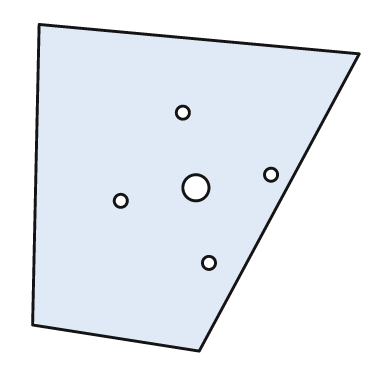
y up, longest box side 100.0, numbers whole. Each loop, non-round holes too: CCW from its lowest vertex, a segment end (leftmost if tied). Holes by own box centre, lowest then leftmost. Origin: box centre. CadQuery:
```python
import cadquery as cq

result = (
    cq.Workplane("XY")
    .moveTo(1.0, -50.0)
    .lineTo(50.0, 41.0)
    .lineTo(-48.0, 50.0)
    .lineTo(-50.0, -42.0)
    .close()
    .moveTo(4.0, -23.0)
    .circle(2.0)
    .moveTo(-23.0, -4.0)
    .circle(2.0)
    .moveTo(0.0, 0.0)
    .circle(4.0)
    .moveTo(23.0, 4.0)
    .circle(2.0)
    .moveTo(-4.0, 23.0)
    .circle(2.0)
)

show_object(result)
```